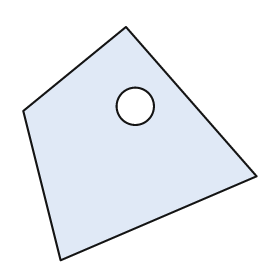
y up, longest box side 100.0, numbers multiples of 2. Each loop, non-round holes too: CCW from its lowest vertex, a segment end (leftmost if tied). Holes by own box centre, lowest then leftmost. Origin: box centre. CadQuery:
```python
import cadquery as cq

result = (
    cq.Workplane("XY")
    .moveTo(-34.0, -50.0)
    .lineTo(50.0, -14.0)
    .lineTo(-6.0, 50.0)
    .lineTo(-50.0, 14.0)
    .close()
    .moveTo(-2.0, 16.0)
    .circle(8.0)
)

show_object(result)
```